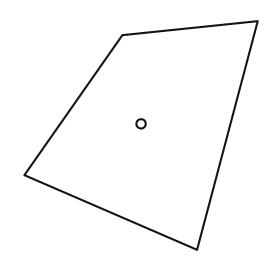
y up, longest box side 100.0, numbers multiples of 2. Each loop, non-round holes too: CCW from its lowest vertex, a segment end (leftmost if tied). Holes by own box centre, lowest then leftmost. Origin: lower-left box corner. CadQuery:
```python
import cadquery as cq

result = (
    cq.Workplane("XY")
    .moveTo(74.0, 0.0)
    .lineTo(100.0, 98.0)
    .lineTo(42.0, 92.0)
    .lineTo(0.0, 32.0)
    .close()
    .moveTo(50.0, 54.0)
    .circle(2.0)
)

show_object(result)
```